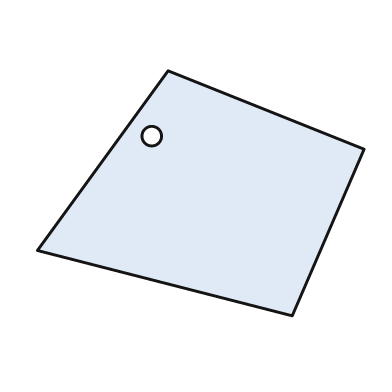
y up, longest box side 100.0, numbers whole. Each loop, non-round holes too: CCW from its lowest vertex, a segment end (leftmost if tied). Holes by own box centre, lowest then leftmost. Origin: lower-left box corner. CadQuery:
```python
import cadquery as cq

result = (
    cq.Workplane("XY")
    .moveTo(78.0, 0.0)
    .lineTo(100.0, 51.0)
    .lineTo(40.0, 75.0)
    .lineTo(0.0, 20.0)
    .close()
    .moveTo(35.0, 55.0)
    .circle(3.0)
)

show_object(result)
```